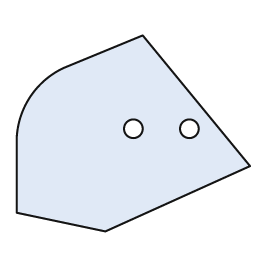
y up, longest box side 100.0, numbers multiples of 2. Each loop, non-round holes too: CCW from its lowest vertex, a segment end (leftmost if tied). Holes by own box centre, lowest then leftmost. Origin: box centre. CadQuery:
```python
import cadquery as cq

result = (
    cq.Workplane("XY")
    .moveTo(-12.0, -42.0)
    .lineTo(50.0, -14.0)
    .lineTo(4.0, 42.0)
    .lineTo(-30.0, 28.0)
    .threePointArc((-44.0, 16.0), (-50.0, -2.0))
    .lineTo(-50.0, -34.0)
    .close()
    .moveTo(0.0, 2.0)
    .circle(4.0)
    .moveTo(24.0, 2.0)
    .circle(4.0)
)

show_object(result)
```